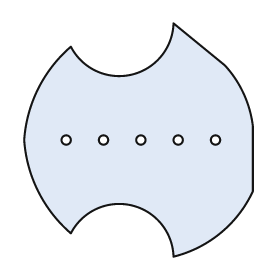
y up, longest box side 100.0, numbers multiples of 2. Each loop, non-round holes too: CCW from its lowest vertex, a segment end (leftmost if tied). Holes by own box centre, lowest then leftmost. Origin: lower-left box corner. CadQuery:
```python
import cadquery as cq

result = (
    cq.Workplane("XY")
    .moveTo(64.0, 0.0)
    .threePointArc((84.0, 10.0), (98.0, 28.0))
    .lineTo(98.0, 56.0)
    .threePointArc((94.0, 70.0), (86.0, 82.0))
    .lineTo(64.0, 100.0)
    .threePointArc((46.0, 78.0), (20.0, 90.0))
    .threePointArc((6.0, 72.0), (0.0, 50.0))
    .threePointArc((6.0, 28.0), (20.0, 10.0))
    .threePointArc((46.0, 22.0), (64.0, 0.0))
    .close()
    .moveTo(18.0, 50.0)
    .circle(2.0)
    .moveTo(34.0, 50.0)
    .circle(2.0)
    .moveTo(50.0, 50.0)
    .circle(2.0)
    .moveTo(66.0, 50.0)
    .circle(2.0)
    .moveTo(82.0, 50.0)
    .circle(2.0)
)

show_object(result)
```